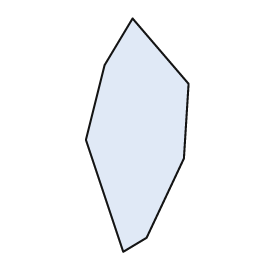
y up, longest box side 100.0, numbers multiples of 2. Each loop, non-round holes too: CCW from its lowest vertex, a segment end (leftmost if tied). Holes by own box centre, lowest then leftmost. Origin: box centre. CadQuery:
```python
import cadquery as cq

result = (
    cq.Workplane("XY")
    .moveTo(-6.0, -50.0)
    .lineTo(4.0, -44.0)
    .lineTo(20.0, -10.0)
    .lineTo(22.0, 22.0)
    .lineTo(-2.0, 50.0)
    .lineTo(-14.0, 30.0)
    .lineTo(-22.0, -2.0)
    .close()
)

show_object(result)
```